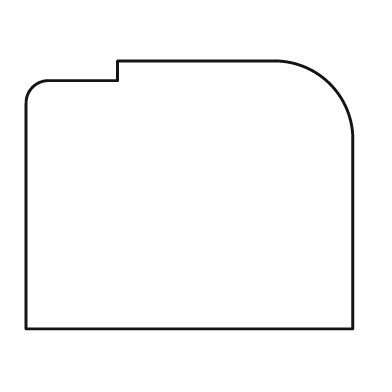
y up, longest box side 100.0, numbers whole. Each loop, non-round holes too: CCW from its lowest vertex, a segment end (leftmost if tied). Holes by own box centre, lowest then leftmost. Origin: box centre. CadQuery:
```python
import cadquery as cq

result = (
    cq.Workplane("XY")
    .moveTo(-50.0, -41.0)
    .lineTo(50.0, -41.0)
    .lineTo(50.0, 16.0)
    .threePointArc((43.0, 34.0), (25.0, 41.0))
    .lineTo(-22.0, 41.0)
    .lineTo(-22.0, 35.0)
    .lineTo(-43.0, 35.0)
    .threePointArc((-48.0, 33.0), (-50.0, 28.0))
    .close()
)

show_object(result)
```